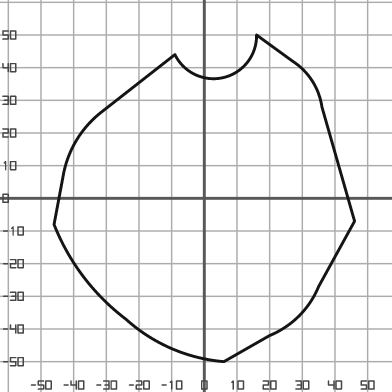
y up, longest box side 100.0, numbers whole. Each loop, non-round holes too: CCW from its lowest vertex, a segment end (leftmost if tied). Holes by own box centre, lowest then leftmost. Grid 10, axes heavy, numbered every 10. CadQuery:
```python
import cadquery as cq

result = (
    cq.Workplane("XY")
    .moveTo(6.0, -50.0)
    .lineTo(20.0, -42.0)
    .threePointArc((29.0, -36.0), (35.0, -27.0))
    .lineTo(46.0, -7.0)
    .lineTo(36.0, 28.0)
    .threePointArc((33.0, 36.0), (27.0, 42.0))
    .lineTo(16.0, 50.0)
    .threePointArc((6.0, 37.0), (-9.0, 44.0))
    .lineTo(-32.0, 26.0)
    .threePointArc((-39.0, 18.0), (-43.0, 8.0))
    .lineTo(-46.0, -8.0)
    .threePointArc((-37.0, -24.0), (-24.0, -37.0))
    .threePointArc((-10.0, -46.0), (6.0, -50.0))
    .close()
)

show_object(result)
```